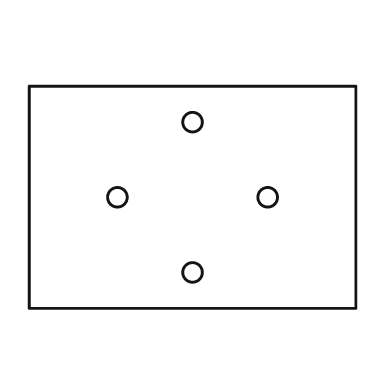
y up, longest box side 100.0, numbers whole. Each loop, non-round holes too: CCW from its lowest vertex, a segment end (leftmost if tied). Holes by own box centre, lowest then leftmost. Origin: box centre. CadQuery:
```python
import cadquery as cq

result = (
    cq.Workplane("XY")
    .moveTo(-50.0, -34.0)
    .lineTo(50.0, -34.0)
    .lineTo(50.0, 34.0)
    .lineTo(-50.0, 34.0)
    .close()
    .moveTo(0.0, -23.0)
    .circle(3.0)
    .moveTo(-23.0, 0.0)
    .circle(3.0)
    .moveTo(23.0, 0.0)
    .circle(3.0)
    .moveTo(0.0, 23.0)
    .circle(3.0)
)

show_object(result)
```